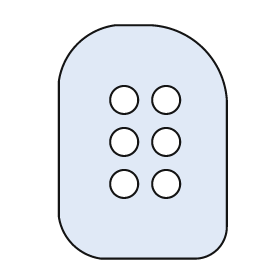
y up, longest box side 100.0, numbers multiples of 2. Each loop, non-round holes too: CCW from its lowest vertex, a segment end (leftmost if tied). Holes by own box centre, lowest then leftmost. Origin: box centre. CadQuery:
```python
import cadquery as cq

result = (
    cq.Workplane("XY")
    .moveTo(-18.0, -50.0)
    .lineTo(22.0, -50.0)
    .threePointArc((32.0, -46.0), (36.0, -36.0))
    .lineTo(36.0, 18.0)
    .threePointArc((26.0, 40.0), (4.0, 50.0))
    .lineTo(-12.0, 50.0)
    .threePointArc((-28.0, 42.0), (-36.0, 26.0))
    .lineTo(-36.0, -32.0)
    .threePointArc((-30.0, -44.0), (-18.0, -50.0))
    .close()
    .moveTo(-8.0, -18.0)
    .circle(6.0)
    .moveTo(10.0, -18.0)
    .circle(6.0)
    .moveTo(-8.0, 0.0)
    .circle(6.0)
    .moveTo(10.0, 0.0)
    .circle(6.0)
    .moveTo(-8.0, 18.0)
    .circle(6.0)
    .moveTo(10.0, 18.0)
    .circle(6.0)
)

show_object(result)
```